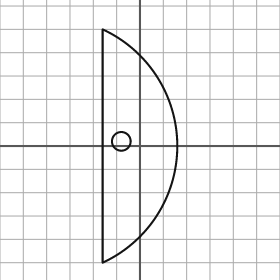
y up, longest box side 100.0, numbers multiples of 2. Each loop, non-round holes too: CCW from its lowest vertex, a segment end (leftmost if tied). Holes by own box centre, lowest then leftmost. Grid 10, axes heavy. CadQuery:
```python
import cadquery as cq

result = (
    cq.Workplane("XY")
    .moveTo(-16.0, -50.0)
    .threePointArc((16.0, 0.0), (-16.0, 50.0))
    .close()
    .moveTo(-8.0, 2.0)
    .circle(4.0)
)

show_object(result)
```